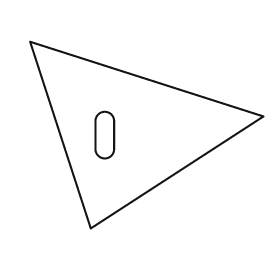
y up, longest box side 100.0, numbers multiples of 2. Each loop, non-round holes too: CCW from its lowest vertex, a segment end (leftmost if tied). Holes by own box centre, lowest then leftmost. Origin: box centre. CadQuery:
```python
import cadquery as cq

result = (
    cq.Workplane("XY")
    .moveTo(-24.0, -40.0)
    .lineTo(50.0, 8.0)
    .lineTo(-50.0, 40.0)
    .close()
    .moveTo(-22.0, -6.0)
    .threePointArc((-18.0, -10.0), (-14.0, -6.0))
    .lineTo(-14.0, 6.0)
    .threePointArc((-18.0, 10.0), (-22.0, 6.0))
    .close()
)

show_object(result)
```